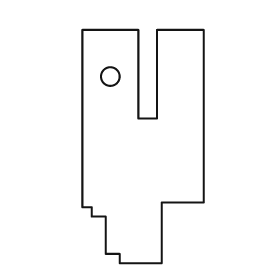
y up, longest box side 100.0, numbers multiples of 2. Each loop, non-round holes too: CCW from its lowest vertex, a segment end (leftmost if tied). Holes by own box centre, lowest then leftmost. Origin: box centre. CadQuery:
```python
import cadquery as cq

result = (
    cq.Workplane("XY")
    .moveTo(-10.0, -50.0)
    .lineTo(8.0, -50.0)
    .lineTo(8.0, -24.0)
    .lineTo(26.0, -24.0)
    .lineTo(26.0, 50.0)
    .lineTo(6.0, 50.0)
    .lineTo(6.0, 12.0)
    .lineTo(-2.0, 12.0)
    .lineTo(-2.0, 50.0)
    .lineTo(-26.0, 50.0)
    .lineTo(-26.0, -26.0)
    .lineTo(-22.0, -26.0)
    .lineTo(-22.0, -30.0)
    .lineTo(-16.0, -30.0)
    .lineTo(-16.0, -46.0)
    .lineTo(-10.0, -46.0)
    .close()
    .moveTo(-14.0, 30.0)
    .circle(4.0)
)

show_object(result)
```